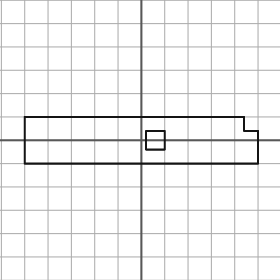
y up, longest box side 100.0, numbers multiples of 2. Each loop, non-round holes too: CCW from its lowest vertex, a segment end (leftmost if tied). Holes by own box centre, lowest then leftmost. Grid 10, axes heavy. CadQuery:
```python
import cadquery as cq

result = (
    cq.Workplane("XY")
    .moveTo(-50.0, -10.0)
    .lineTo(50.0, -10.0)
    .lineTo(50.0, 4.0)
    .lineTo(44.0, 4.0)
    .lineTo(44.0, 10.0)
    .lineTo(-50.0, 10.0)
    .close()
    .moveTo(2.0, -4.0)
    .lineTo(10.0, -4.0)
    .lineTo(10.0, 4.0)
    .lineTo(2.0, 4.0)
    .close()
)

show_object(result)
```